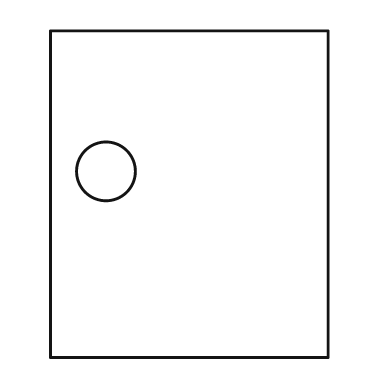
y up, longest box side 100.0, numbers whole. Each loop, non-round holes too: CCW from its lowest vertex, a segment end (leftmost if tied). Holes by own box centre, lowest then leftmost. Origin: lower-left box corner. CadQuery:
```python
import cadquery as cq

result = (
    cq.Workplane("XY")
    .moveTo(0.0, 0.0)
    .lineTo(85.0, 0.0)
    .lineTo(85.0, 100.0)
    .lineTo(0.0, 100.0)
    .close()
    .moveTo(17.0, 57.0)
    .circle(9.0)
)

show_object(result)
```